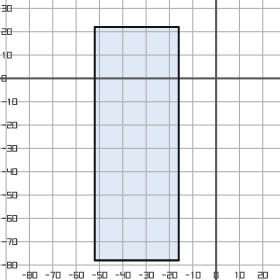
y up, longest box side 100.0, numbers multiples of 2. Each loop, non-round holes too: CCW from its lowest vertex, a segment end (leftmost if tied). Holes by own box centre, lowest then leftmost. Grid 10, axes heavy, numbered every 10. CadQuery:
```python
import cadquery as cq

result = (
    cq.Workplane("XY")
    .moveTo(-52.0, -78.0)
    .lineTo(-16.0, -78.0)
    .lineTo(-16.0, 22.0)
    .lineTo(-52.0, 22.0)
    .close()
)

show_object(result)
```